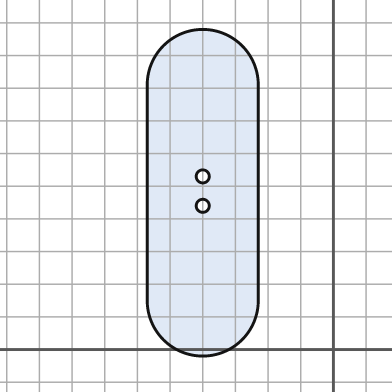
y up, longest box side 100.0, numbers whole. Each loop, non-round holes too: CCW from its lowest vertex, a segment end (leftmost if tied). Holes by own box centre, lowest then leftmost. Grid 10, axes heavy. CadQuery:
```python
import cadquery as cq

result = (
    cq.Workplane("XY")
    .moveTo(-57.0, 15.0)
    .threePointArc((-40.0, -2.0), (-23.0, 15.0))
    .lineTo(-23.0, 81.0)
    .threePointArc((-40.0, 98.0), (-57.0, 81.0))
    .close()
    .moveTo(-40.0, 44.0)
    .circle(2.0)
    .moveTo(-40.0, 53.0)
    .circle(2.0)
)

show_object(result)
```